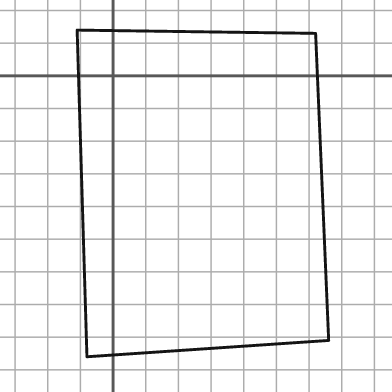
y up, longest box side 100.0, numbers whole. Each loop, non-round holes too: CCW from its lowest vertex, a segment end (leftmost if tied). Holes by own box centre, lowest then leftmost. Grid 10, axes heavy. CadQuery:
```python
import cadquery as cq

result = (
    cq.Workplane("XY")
    .moveTo(-8.0, -86.0)
    .lineTo(66.0, -81.0)
    .lineTo(62.0, 13.0)
    .lineTo(-11.0, 14.0)
    .close()
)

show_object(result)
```